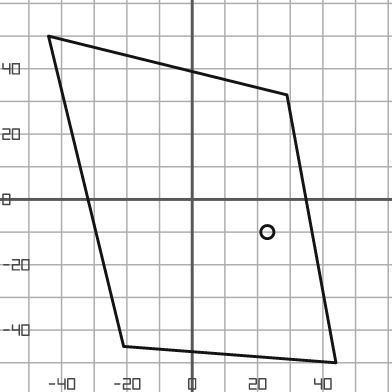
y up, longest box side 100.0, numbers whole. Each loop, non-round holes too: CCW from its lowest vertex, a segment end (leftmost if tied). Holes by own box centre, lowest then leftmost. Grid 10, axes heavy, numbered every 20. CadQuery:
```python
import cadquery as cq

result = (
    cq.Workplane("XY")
    .moveTo(44.0, -50.0)
    .lineTo(29.0, 32.0)
    .lineTo(-44.0, 50.0)
    .lineTo(-21.0, -45.0)
    .close()
    .moveTo(23.0, -10.0)
    .circle(2.0)
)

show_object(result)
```